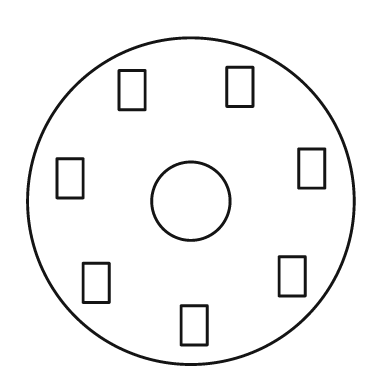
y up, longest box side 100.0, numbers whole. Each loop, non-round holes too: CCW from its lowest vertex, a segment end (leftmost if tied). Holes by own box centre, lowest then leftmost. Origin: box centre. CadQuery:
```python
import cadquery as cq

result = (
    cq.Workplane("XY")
    .moveTo(0.0, 0.0)
    .circle(50.0)
    .moveTo(-3.0, -44.0)
    .lineTo(5.0, -44.0)
    .lineTo(5.0, -32.0)
    .lineTo(-3.0, -32.0)
    .close()
    .moveTo(-33.0, -31.0)
    .lineTo(-25.0, -31.0)
    .lineTo(-25.0, -19.0)
    .lineTo(-33.0, -19.0)
    .close()
    .moveTo(27.0, -29.0)
    .lineTo(35.0, -29.0)
    .lineTo(35.0, -17.0)
    .lineTo(27.0, -17.0)
    .close()
    .moveTo(0.0, 0.0)
    .circle(12.0)
    .moveTo(-41.0, 1.0)
    .lineTo(-33.0, 1.0)
    .lineTo(-33.0, 13.0)
    .lineTo(-41.0, 13.0)
    .close()
    .moveTo(33.0, 4.0)
    .lineTo(41.0, 4.0)
    .lineTo(41.0, 16.0)
    .lineTo(33.0, 16.0)
    .close()
    .moveTo(-22.0, 28.0)
    .lineTo(-14.0, 28.0)
    .lineTo(-14.0, 40.0)
    .lineTo(-22.0, 40.0)
    .close()
    .moveTo(11.0, 29.0)
    .lineTo(19.0, 29.0)
    .lineTo(19.0, 41.0)
    .lineTo(11.0, 41.0)
    .close()
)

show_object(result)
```